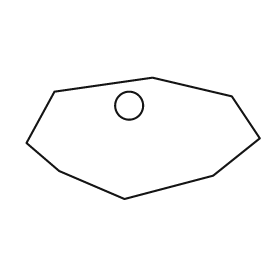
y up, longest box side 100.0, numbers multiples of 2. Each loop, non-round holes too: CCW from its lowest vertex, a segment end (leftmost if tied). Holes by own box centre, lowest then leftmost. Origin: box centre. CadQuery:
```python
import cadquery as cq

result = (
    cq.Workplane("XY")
    .moveTo(-8.0, -26.0)
    .lineTo(30.0, -16.0)
    .lineTo(50.0, 0.0)
    .lineTo(38.0, 18.0)
    .lineTo(4.0, 26.0)
    .lineTo(-38.0, 20.0)
    .lineTo(-50.0, -2.0)
    .lineTo(-36.0, -14.0)
    .close()
    .moveTo(-6.0, 14.0)
    .circle(6.0)
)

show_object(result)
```